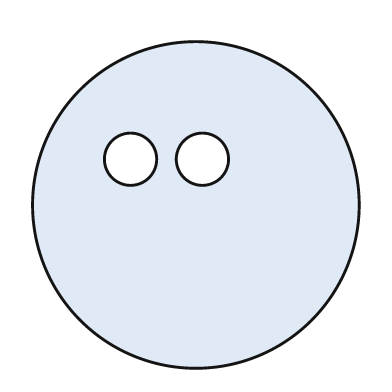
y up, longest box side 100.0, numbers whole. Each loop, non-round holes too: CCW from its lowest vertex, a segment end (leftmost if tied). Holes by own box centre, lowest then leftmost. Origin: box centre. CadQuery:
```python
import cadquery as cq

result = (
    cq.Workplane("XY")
    .moveTo(0.0, 0.0)
    .circle(50.0)
    .moveTo(-20.0, 14.0)
    .circle(8.0)
    .moveTo(2.0, 14.0)
    .circle(8.0)
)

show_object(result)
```